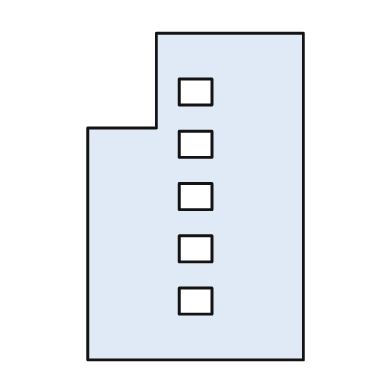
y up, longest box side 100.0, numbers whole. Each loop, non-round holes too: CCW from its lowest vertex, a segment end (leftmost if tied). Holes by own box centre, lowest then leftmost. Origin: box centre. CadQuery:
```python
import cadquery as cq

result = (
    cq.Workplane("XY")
    .moveTo(-33.0, -50.0)
    .lineTo(33.0, -50.0)
    .lineTo(33.0, 50.0)
    .lineTo(-12.0, 50.0)
    .lineTo(-12.0, 21.0)
    .lineTo(-33.0, 21.0)
    .close()
    .moveTo(-5.0, -36.0)
    .lineTo(5.0, -36.0)
    .lineTo(5.0, -28.0)
    .lineTo(-5.0, -28.0)
    .close()
    .moveTo(-5.0, -20.0)
    .lineTo(5.0, -20.0)
    .lineTo(5.0, -12.0)
    .lineTo(-5.0, -12.0)
    .close()
    .moveTo(-5.0, -4.0)
    .lineTo(5.0, -4.0)
    .lineTo(5.0, 4.0)
    .lineTo(-5.0, 4.0)
    .close()
    .moveTo(-5.0, 12.0)
    .lineTo(5.0, 12.0)
    .lineTo(5.0, 20.0)
    .lineTo(-5.0, 20.0)
    .close()
    .moveTo(-5.0, 28.0)
    .lineTo(5.0, 28.0)
    .lineTo(5.0, 36.0)
    .lineTo(-5.0, 36.0)
    .close()
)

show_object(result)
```